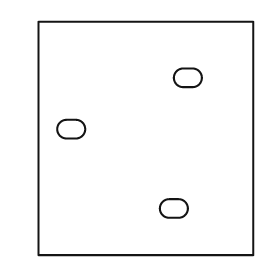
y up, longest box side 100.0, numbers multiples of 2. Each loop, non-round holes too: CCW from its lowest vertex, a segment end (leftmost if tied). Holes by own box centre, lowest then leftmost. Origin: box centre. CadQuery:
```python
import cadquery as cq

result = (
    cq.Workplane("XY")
    .moveTo(-46.0, -50.0)
    .lineTo(46.0, -50.0)
    .lineTo(46.0, 50.0)
    .lineTo(-46.0, 50.0)
    .close()
    .moveTo(10.0, -34.0)
    .lineTo(14.0, -34.0)
    .threePointArc((18.0, -30.0), (14.0, -26.0))
    .lineTo(10.0, -26.0)
    .threePointArc((6.0, -30.0), (10.0, -34.0))
    .close()
    .moveTo(-34.0, 0.0)
    .lineTo(-30.0, 0.0)
    .threePointArc((-26.0, 4.0), (-30.0, 8.0))
    .lineTo(-34.0, 8.0)
    .threePointArc((-38.0, 4.0), (-34.0, 0.0))
    .close()
    .moveTo(16.0, 22.0)
    .lineTo(20.0, 22.0)
    .threePointArc((24.0, 26.0), (20.0, 30.0))
    .lineTo(16.0, 30.0)
    .threePointArc((12.0, 26.0), (16.0, 22.0))
    .close()
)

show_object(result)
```